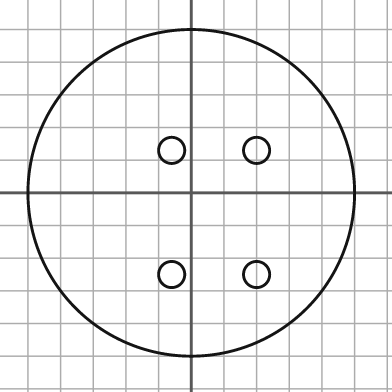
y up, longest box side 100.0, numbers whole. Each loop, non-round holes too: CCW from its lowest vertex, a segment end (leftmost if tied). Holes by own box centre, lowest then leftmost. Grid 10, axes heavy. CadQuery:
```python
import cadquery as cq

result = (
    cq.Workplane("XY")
    .moveTo(0.0, 0.0)
    .circle(50.0)
    .moveTo(-6.0, -25.0)
    .circle(4.0)
    .moveTo(20.0, -25.0)
    .circle(4.0)
    .moveTo(-6.0, 13.0)
    .circle(4.0)
    .moveTo(20.0, 13.0)
    .circle(4.0)
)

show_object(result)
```